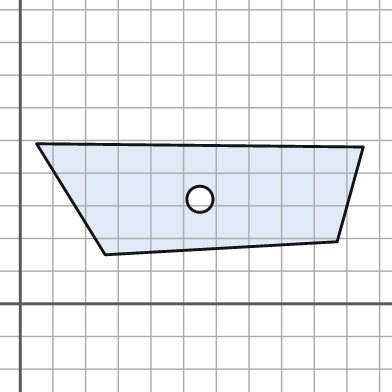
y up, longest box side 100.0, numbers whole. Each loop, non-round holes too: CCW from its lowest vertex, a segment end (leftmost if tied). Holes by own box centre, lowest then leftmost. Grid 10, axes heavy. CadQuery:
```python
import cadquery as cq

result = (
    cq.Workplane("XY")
    .moveTo(26.0, 15.0)
    .lineTo(97.0, 19.0)
    .lineTo(105.0, 48.0)
    .lineTo(5.0, 49.0)
    .close()
    .moveTo(55.0, 32.0)
    .circle(4.0)
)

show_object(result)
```